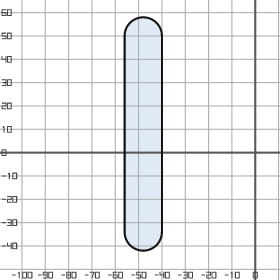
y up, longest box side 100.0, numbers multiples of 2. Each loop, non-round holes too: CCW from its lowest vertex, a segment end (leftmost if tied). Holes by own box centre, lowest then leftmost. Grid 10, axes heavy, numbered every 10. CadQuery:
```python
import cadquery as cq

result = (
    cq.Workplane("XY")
    .moveTo(-56.0, -34.0)
    .threePointArc((-48.0, -42.0), (-40.0, -34.0))
    .lineTo(-40.0, 50.0)
    .threePointArc((-48.0, 58.0), (-56.0, 50.0))
    .close()
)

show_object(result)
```